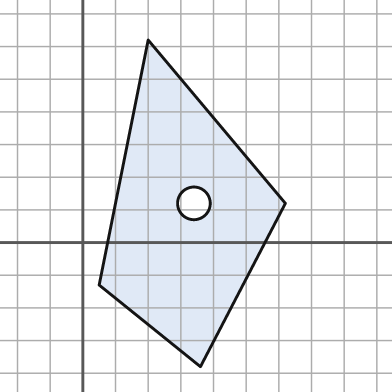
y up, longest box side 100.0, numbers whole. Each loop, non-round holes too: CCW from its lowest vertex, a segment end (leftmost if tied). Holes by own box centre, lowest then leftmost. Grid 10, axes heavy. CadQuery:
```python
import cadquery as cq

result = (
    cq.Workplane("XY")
    .moveTo(36.0, -38.0)
    .lineTo(62.0, 12.0)
    .lineTo(20.0, 62.0)
    .lineTo(5.0, -13.0)
    .close()
    .moveTo(34.0, 12.0)
    .circle(5.0)
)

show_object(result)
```